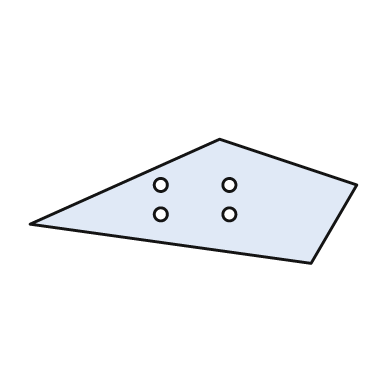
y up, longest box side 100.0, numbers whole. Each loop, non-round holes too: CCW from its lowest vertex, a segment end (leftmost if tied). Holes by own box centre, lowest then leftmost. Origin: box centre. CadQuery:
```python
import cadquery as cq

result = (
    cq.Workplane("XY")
    .moveTo(36.0, -19.0)
    .lineTo(50.0, 5.0)
    .lineTo(8.0, 19.0)
    .lineTo(-50.0, -7.0)
    .close()
    .moveTo(-10.0, -4.0)
    .circle(2.0)
    .moveTo(11.0, -4.0)
    .circle(2.0)
    .moveTo(-10.0, 5.0)
    .circle(2.0)
    .moveTo(11.0, 5.0)
    .circle(2.0)
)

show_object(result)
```